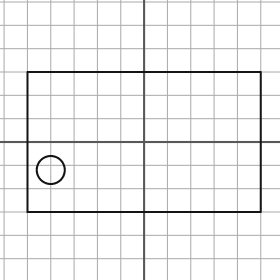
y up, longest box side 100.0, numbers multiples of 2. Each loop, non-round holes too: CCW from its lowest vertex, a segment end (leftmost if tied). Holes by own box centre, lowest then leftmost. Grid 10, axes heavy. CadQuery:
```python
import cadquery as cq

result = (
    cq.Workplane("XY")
    .moveTo(-50.0, -30.0)
    .lineTo(50.0, -30.0)
    .lineTo(50.0, 30.0)
    .lineTo(-50.0, 30.0)
    .close()
    .moveTo(-40.0, -12.0)
    .circle(6.0)
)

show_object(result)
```